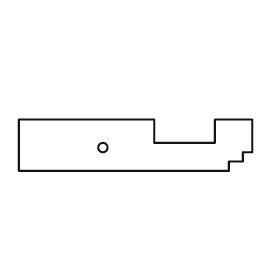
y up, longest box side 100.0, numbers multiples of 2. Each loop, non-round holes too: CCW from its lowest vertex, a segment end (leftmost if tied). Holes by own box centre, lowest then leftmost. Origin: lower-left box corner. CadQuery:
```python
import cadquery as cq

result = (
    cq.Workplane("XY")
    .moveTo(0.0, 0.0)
    .lineTo(90.0, 0.0)
    .lineTo(90.0, 4.0)
    .lineTo(96.0, 4.0)
    .lineTo(96.0, 8.0)
    .lineTo(100.0, 8.0)
    .lineTo(100.0, 22.0)
    .lineTo(84.0, 22.0)
    .lineTo(84.0, 12.0)
    .lineTo(58.0, 12.0)
    .lineTo(58.0, 22.0)
    .lineTo(0.0, 22.0)
    .close()
    .moveTo(36.0, 10.0)
    .circle(2.0)
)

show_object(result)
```